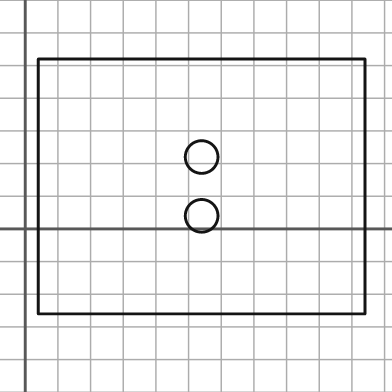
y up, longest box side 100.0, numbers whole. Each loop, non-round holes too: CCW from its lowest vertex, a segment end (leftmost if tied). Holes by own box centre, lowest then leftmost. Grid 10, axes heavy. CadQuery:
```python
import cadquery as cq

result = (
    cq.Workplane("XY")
    .moveTo(4.0, -26.0)
    .lineTo(104.0, -26.0)
    .lineTo(104.0, 52.0)
    .lineTo(4.0, 52.0)
    .close()
    .moveTo(54.0, 4.0)
    .circle(5.0)
    .moveTo(54.0, 22.0)
    .circle(5.0)
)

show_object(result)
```